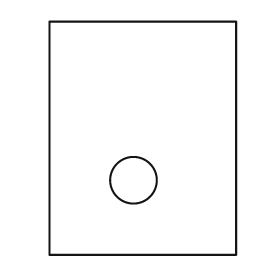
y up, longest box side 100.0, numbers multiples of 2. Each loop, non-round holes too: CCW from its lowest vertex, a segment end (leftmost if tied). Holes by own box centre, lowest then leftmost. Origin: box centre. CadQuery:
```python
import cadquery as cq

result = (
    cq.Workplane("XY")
    .moveTo(-40.0, -50.0)
    .lineTo(40.0, -50.0)
    .lineTo(40.0, 50.0)
    .lineTo(-40.0, 50.0)
    .close()
    .moveTo(-4.0, -18.0)
    .circle(10.0)
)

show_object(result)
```